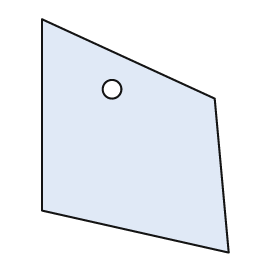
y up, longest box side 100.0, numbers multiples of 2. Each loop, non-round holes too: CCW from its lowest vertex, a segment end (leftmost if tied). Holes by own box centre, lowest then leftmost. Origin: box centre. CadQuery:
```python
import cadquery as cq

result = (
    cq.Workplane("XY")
    .moveTo(40.0, -50.0)
    .lineTo(34.0, 16.0)
    .lineTo(-40.0, 50.0)
    .lineTo(-40.0, -32.0)
    .close()
    .moveTo(-10.0, 20.0)
    .circle(4.0)
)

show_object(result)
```